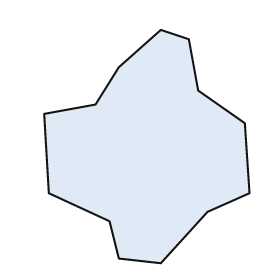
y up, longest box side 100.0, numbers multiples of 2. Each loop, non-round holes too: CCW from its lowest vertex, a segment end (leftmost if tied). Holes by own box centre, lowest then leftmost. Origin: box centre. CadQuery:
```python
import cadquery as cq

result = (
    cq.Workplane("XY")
    .moveTo(6.0, -50.0)
    .lineTo(26.0, -28.0)
    .lineTo(44.0, -20.0)
    .lineTo(42.0, 10.0)
    .lineTo(22.0, 24.0)
    .lineTo(18.0, 46.0)
    .lineTo(6.0, 50.0)
    .lineTo(-12.0, 34.0)
    .lineTo(-22.0, 18.0)
    .lineTo(-44.0, 14.0)
    .lineTo(-42.0, -20.0)
    .lineTo(-16.0, -32.0)
    .lineTo(-12.0, -48.0)
    .close()
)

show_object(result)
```